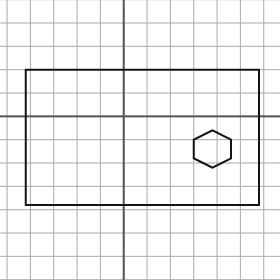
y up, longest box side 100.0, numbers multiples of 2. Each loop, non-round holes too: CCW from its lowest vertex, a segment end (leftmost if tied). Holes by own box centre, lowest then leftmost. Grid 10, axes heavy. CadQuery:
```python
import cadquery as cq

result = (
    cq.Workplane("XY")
    .moveTo(-42.0, -38.0)
    .lineTo(58.0, -38.0)
    .lineTo(58.0, 20.0)
    .lineTo(-42.0, 20.0)
    .close()
    .moveTo(38.0, -22.0)
    .lineTo(46.0, -18.0)
    .lineTo(46.0, -10.0)
    .lineTo(38.0, -6.0)
    .lineTo(30.0, -10.0)
    .lineTo(30.0, -18.0)
    .close()
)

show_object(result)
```